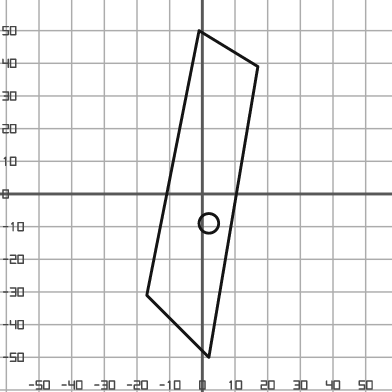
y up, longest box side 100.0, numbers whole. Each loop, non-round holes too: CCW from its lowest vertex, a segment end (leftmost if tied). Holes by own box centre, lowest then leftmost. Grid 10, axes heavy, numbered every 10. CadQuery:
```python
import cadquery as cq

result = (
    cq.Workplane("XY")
    .moveTo(2.0, -50.0)
    .lineTo(17.0, 39.0)
    .lineTo(-1.0, 50.0)
    .lineTo(-17.0, -31.0)
    .close()
    .moveTo(2.0, -9.0)
    .circle(3.0)
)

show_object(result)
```